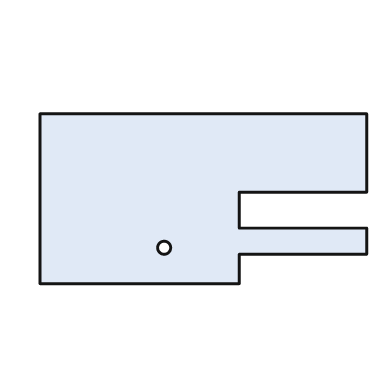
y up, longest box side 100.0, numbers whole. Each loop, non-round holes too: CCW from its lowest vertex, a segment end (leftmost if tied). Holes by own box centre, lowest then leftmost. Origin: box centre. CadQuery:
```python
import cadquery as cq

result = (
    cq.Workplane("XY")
    .moveTo(-50.0, -26.0)
    .lineTo(11.0, -26.0)
    .lineTo(11.0, -17.0)
    .lineTo(50.0, -17.0)
    .lineTo(50.0, -9.0)
    .lineTo(11.0, -9.0)
    .lineTo(11.0, 2.0)
    .lineTo(50.0, 2.0)
    .lineTo(50.0, 26.0)
    .lineTo(-50.0, 26.0)
    .close()
    .moveTo(-12.0, -15.0)
    .circle(2.0)
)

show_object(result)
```